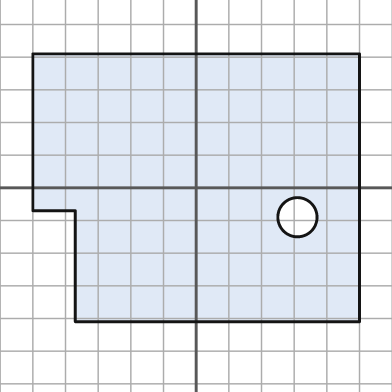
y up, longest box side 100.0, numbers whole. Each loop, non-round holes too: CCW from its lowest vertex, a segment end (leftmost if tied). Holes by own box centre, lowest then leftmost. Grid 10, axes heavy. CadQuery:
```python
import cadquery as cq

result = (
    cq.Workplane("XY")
    .moveTo(-37.0, -41.0)
    .lineTo(50.0, -41.0)
    .lineTo(50.0, 41.0)
    .lineTo(-50.0, 41.0)
    .lineTo(-50.0, -7.0)
    .lineTo(-37.0, -7.0)
    .close()
    .moveTo(31.0, -9.0)
    .circle(6.0)
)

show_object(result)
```